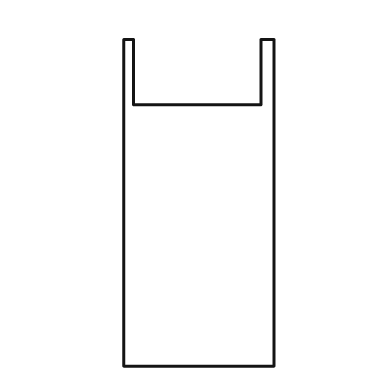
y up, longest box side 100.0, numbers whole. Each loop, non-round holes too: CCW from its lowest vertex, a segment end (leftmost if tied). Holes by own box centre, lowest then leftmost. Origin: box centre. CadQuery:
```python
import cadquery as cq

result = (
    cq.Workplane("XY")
    .moveTo(-23.0, -50.0)
    .lineTo(23.0, -50.0)
    .lineTo(23.0, 50.0)
    .lineTo(19.0, 50.0)
    .lineTo(19.0, 30.0)
    .lineTo(-20.0, 30.0)
    .lineTo(-20.0, 50.0)
    .lineTo(-23.0, 50.0)
    .close()
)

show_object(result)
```